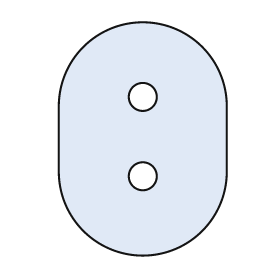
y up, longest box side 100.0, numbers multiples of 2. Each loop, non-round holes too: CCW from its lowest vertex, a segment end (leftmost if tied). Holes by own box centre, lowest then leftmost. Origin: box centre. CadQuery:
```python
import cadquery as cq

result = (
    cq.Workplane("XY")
    .moveTo(-36.0, -14.0)
    .threePointArc((0.0, -50.0), (36.0, -14.0))
    .lineTo(36.0, 14.0)
    .threePointArc((0.0, 50.0), (-36.0, 14.0))
    .close()
    .moveTo(0.0, -16.0)
    .circle(6.0)
    .moveTo(0.0, 18.0)
    .circle(6.0)
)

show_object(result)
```